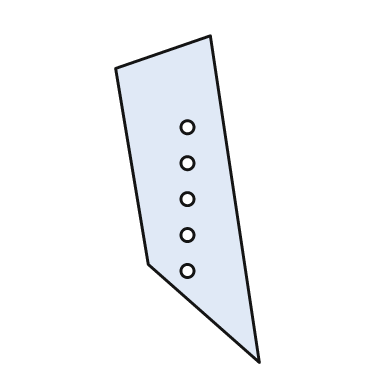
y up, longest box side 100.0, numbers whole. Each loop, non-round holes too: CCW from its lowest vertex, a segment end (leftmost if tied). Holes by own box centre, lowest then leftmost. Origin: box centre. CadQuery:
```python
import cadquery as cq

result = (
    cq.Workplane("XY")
    .moveTo(22.0, -50.0)
    .lineTo(7.0, 50.0)
    .lineTo(-22.0, 40.0)
    .lineTo(-12.0, -20.0)
    .close()
    .moveTo(0.0, -22.0)
    .circle(2.0)
    .moveTo(0.0, -11.0)
    .circle(2.0)
    .moveTo(0.0, 0.0)
    .circle(2.0)
    .moveTo(0.0, 11.0)
    .circle(2.0)
    .moveTo(0.0, 22.0)
    .circle(2.0)
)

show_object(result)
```